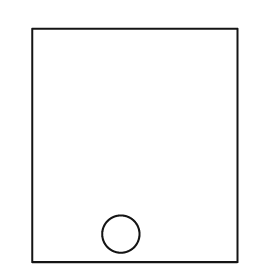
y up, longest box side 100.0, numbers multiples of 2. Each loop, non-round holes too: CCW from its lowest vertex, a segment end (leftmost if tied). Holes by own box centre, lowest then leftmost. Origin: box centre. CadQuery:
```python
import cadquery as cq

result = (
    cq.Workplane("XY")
    .moveTo(-44.0, -50.0)
    .lineTo(44.0, -50.0)
    .lineTo(44.0, 50.0)
    .lineTo(-44.0, 50.0)
    .close()
    .moveTo(-6.0, -38.0)
    .circle(8.0)
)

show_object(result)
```